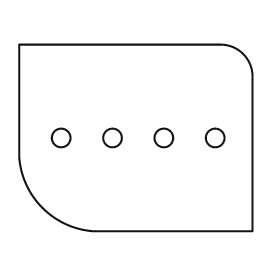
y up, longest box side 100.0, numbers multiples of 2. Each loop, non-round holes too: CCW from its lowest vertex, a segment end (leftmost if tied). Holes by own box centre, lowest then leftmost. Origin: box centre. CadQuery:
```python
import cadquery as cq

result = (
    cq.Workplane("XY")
    .moveTo(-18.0, -40.0)
    .lineTo(50.0, -40.0)
    .lineTo(50.0, 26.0)
    .threePointArc((46.0, 36.0), (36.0, 40.0))
    .lineTo(-50.0, 40.0)
    .lineTo(-50.0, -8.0)
    .threePointArc((-40.0, -30.0), (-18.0, -40.0))
    .close()
    .moveTo(-32.0, 0.0)
    .circle(4.0)
    .moveTo(-10.0, 0.0)
    .circle(4.0)
    .moveTo(12.0, 0.0)
    .circle(4.0)
    .moveTo(34.0, 0.0)
    .circle(4.0)
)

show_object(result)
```